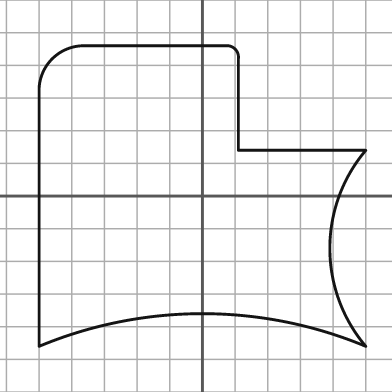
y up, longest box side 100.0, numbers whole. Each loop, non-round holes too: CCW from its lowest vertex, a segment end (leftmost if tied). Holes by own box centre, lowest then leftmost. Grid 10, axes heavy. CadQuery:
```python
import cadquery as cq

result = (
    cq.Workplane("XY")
    .moveTo(-50.0, -46.0)
    .threePointArc((0.0, -36.0), (50.0, -46.0))
    .threePointArc((39.0, -16.0), (50.0, 14.0))
    .lineTo(11.0, 14.0)
    .lineTo(11.0, 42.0)
    .threePointArc((10.0, 45.0), (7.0, 46.0))
    .lineTo(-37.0, 46.0)
    .threePointArc((-46.0, 42.0), (-50.0, 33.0))
    .close()
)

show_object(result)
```